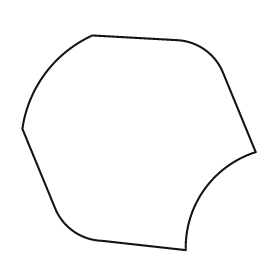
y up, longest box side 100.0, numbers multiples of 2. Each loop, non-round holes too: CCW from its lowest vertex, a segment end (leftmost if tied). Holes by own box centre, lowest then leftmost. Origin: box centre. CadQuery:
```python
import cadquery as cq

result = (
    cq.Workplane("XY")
    .moveTo(20.0, -46.0)
    .threePointArc((28.0, -20.0), (50.0, -4.0))
    .lineTo(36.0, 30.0)
    .threePointArc((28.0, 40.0), (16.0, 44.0))
    .lineTo(-20.0, 46.0)
    .threePointArc((-40.0, 30.0), (-50.0, 6.0))
    .lineTo(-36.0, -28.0)
    .threePointArc((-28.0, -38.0), (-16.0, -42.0))
    .close()
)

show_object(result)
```